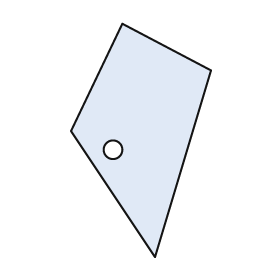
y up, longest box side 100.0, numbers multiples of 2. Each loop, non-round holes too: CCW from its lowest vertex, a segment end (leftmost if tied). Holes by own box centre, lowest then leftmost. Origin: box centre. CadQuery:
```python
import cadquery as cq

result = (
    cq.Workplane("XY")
    .moveTo(6.0, -50.0)
    .lineTo(30.0, 30.0)
    .lineTo(-8.0, 50.0)
    .lineTo(-30.0, 4.0)
    .close()
    .moveTo(-12.0, -4.0)
    .circle(4.0)
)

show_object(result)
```